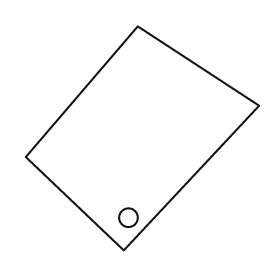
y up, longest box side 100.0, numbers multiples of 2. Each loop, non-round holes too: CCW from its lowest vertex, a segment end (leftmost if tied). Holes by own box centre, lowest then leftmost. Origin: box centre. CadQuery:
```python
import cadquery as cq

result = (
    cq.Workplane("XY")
    .moveTo(-8.0, -48.0)
    .lineTo(50.0, 14.0)
    .lineTo(-2.0, 48.0)
    .lineTo(-50.0, -8.0)
    .close()
    .moveTo(-6.0, -34.0)
    .circle(4.0)
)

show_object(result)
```